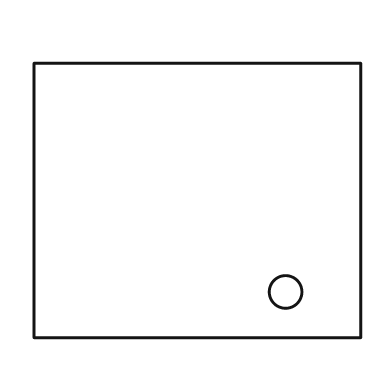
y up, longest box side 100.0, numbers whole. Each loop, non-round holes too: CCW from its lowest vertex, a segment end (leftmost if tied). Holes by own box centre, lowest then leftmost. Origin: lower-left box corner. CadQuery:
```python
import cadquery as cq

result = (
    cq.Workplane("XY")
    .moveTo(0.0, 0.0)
    .lineTo(100.0, 0.0)
    .lineTo(100.0, 84.0)
    .lineTo(0.0, 84.0)
    .close()
    .moveTo(77.0, 14.0)
    .circle(5.0)
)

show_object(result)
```